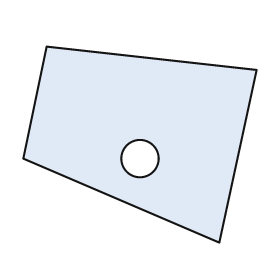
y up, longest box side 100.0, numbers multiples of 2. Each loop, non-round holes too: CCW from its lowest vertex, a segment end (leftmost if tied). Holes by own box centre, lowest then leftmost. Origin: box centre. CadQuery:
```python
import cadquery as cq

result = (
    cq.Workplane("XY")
    .moveTo(34.0, -42.0)
    .lineTo(50.0, 32.0)
    .lineTo(-40.0, 42.0)
    .lineTo(-50.0, -6.0)
    .close()
    .moveTo(0.0, -6.0)
    .circle(8.0)
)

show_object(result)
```